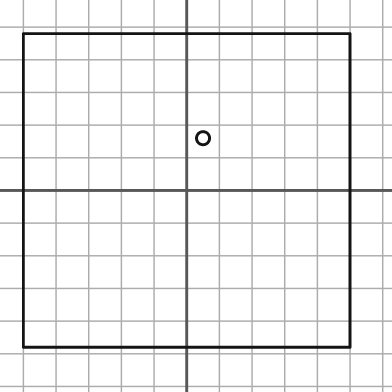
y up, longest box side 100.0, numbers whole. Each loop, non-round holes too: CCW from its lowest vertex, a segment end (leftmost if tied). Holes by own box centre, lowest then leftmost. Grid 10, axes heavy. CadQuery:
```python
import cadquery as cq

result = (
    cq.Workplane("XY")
    .moveTo(-50.0, -48.0)
    .lineTo(50.0, -48.0)
    .lineTo(50.0, 48.0)
    .lineTo(-50.0, 48.0)
    .close()
    .moveTo(5.0, 16.0)
    .circle(2.0)
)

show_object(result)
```